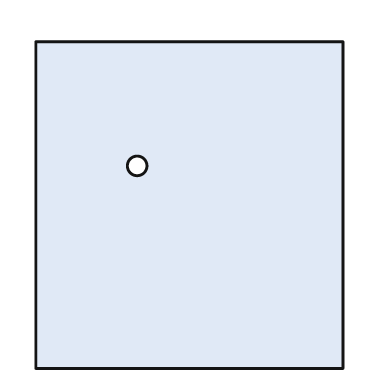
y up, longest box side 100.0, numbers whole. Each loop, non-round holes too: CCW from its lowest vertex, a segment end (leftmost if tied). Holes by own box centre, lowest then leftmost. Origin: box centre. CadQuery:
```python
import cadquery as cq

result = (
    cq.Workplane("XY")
    .moveTo(-47.0, -50.0)
    .lineTo(47.0, -50.0)
    .lineTo(47.0, 50.0)
    .lineTo(-47.0, 50.0)
    .close()
    .moveTo(-16.0, 12.0)
    .circle(3.0)
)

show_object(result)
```